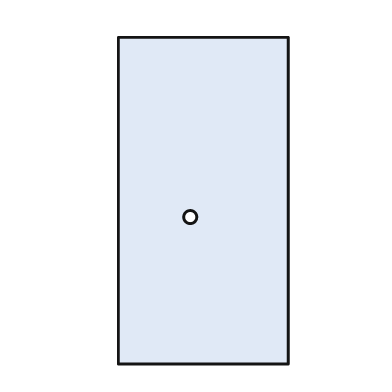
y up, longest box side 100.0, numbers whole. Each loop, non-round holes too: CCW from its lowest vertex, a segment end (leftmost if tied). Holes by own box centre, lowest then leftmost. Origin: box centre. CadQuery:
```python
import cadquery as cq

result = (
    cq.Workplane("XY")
    .moveTo(-26.0, -50.0)
    .lineTo(26.0, -50.0)
    .lineTo(26.0, 50.0)
    .lineTo(-26.0, 50.0)
    .close()
    .moveTo(-4.0, -5.0)
    .circle(2.0)
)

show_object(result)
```